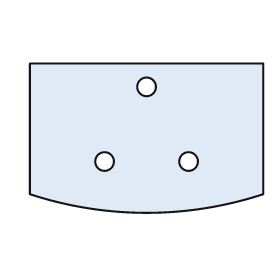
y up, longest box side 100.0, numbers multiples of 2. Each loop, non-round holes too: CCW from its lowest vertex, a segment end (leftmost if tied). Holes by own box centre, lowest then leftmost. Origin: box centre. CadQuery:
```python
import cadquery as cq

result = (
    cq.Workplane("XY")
    .moveTo(-50.0, -24.0)
    .threePointArc((0.0, -32.0), (50.0, -24.0))
    .lineTo(50.0, 32.0)
    .lineTo(-50.0, 32.0)
    .close()
    .moveTo(-18.0, -10.0)
    .circle(4.0)
    .moveTo(18.0, -10.0)
    .circle(4.0)
    .moveTo(0.0, 22.0)
    .circle(4.0)
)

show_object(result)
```